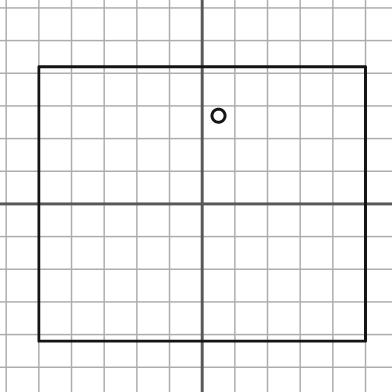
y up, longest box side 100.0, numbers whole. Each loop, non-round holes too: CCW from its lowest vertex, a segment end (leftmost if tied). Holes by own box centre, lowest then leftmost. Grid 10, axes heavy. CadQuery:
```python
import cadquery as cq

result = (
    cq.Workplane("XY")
    .moveTo(-50.0, -42.0)
    .lineTo(50.0, -42.0)
    .lineTo(50.0, 42.0)
    .lineTo(-50.0, 42.0)
    .close()
    .moveTo(5.0, 27.0)
    .circle(2.0)
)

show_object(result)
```